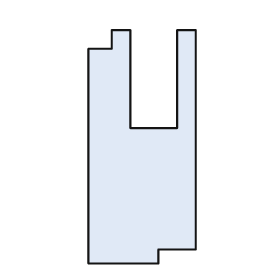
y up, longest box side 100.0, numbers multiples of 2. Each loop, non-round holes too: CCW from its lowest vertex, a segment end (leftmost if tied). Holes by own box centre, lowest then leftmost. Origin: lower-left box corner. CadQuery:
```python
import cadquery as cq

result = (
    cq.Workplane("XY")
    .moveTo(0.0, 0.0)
    .lineTo(30.0, 0.0)
    .lineTo(30.0, 6.0)
    .lineTo(46.0, 6.0)
    .lineTo(46.0, 100.0)
    .lineTo(38.0, 100.0)
    .lineTo(38.0, 58.0)
    .lineTo(18.0, 58.0)
    .lineTo(18.0, 100.0)
    .lineTo(10.0, 100.0)
    .lineTo(10.0, 92.0)
    .lineTo(0.0, 92.0)
    .close()
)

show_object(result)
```